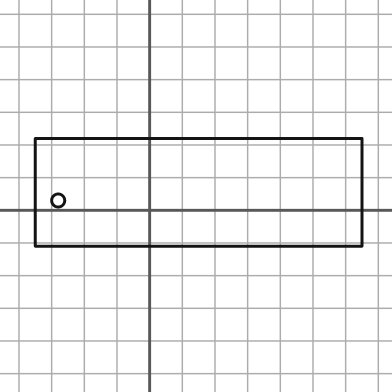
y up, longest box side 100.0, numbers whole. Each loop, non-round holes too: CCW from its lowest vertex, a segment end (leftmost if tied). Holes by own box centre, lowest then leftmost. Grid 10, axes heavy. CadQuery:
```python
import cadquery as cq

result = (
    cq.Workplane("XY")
    .moveTo(-35.0, -11.0)
    .lineTo(65.0, -11.0)
    .lineTo(65.0, 22.0)
    .lineTo(-35.0, 22.0)
    .close()
    .moveTo(-28.0, 3.0)
    .circle(2.0)
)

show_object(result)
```